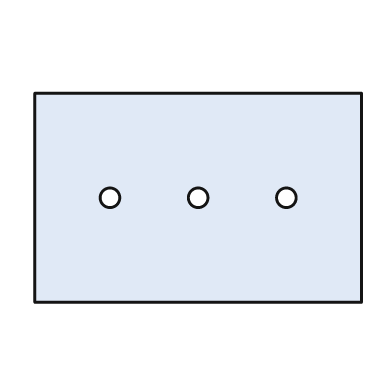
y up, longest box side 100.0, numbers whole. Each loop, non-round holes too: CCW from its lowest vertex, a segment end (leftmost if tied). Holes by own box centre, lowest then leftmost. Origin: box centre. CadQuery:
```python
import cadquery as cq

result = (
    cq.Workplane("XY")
    .moveTo(-50.0, -32.0)
    .lineTo(50.0, -32.0)
    .lineTo(50.0, 32.0)
    .lineTo(-50.0, 32.0)
    .close()
    .moveTo(-27.0, 0.0)
    .circle(3.0)
    .moveTo(0.0, 0.0)
    .circle(3.0)
    .moveTo(27.0, 0.0)
    .circle(3.0)
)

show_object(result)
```